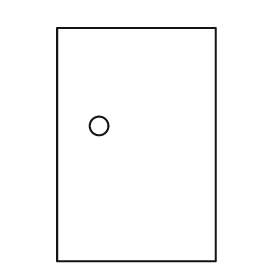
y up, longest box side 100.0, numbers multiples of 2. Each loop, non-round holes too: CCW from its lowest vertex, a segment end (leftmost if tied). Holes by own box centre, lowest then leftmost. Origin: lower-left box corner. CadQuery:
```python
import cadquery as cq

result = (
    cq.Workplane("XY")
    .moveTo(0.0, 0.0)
    .lineTo(68.0, 0.0)
    .lineTo(68.0, 100.0)
    .lineTo(0.0, 100.0)
    .close()
    .moveTo(18.0, 58.0)
    .circle(4.0)
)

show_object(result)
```